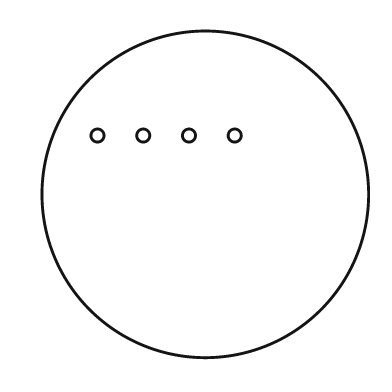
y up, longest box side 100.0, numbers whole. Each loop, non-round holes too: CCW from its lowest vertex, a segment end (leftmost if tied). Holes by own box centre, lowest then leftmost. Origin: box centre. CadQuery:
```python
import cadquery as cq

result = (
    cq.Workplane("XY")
    .moveTo(0.0, 0.0)
    .circle(50.0)
    .moveTo(-33.0, 18.0)
    .circle(2.0)
    .moveTo(-19.0, 18.0)
    .circle(2.0)
    .moveTo(-5.0, 18.0)
    .circle(2.0)
    .moveTo(9.0, 18.0)
    .circle(2.0)
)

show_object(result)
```